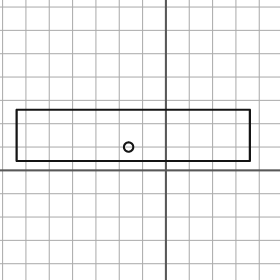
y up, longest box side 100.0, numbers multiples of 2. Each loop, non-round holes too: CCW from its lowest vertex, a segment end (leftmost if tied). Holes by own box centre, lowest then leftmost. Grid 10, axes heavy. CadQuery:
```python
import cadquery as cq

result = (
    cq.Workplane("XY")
    .moveTo(-64.0, 4.0)
    .lineTo(36.0, 4.0)
    .lineTo(36.0, 26.0)
    .lineTo(-64.0, 26.0)
    .close()
    .moveTo(-16.0, 10.0)
    .circle(2.0)
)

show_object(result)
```